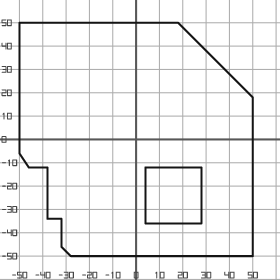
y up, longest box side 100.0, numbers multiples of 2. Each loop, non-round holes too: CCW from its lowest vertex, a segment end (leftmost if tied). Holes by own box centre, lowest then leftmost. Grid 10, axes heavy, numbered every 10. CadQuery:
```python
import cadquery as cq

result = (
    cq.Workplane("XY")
    .moveTo(-28.0, -50.0)
    .lineTo(50.0, -50.0)
    .lineTo(50.0, 18.0)
    .lineTo(18.0, 50.0)
    .lineTo(-50.0, 50.0)
    .lineTo(-50.0, -6.0)
    .lineTo(-46.0, -12.0)
    .lineTo(-38.0, -12.0)
    .lineTo(-38.0, -34.0)
    .lineTo(-32.0, -34.0)
    .lineTo(-32.0, -46.0)
    .close()
    .moveTo(4.0, -36.0)
    .lineTo(28.0, -36.0)
    .lineTo(28.0, -12.0)
    .lineTo(4.0, -12.0)
    .close()
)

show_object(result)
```